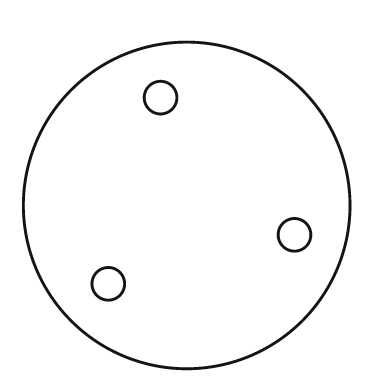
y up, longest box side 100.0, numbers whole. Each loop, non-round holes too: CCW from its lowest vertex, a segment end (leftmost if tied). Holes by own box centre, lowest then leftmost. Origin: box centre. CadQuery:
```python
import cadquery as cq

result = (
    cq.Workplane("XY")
    .moveTo(0.0, 0.0)
    .circle(50.0)
    .moveTo(-24.0, -24.0)
    .circle(5.0)
    .moveTo(33.0, -9.0)
    .circle(5.0)
    .moveTo(-8.0, 33.0)
    .circle(5.0)
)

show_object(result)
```